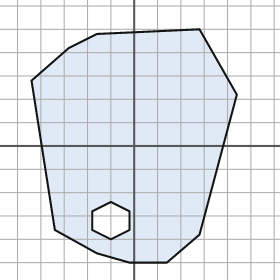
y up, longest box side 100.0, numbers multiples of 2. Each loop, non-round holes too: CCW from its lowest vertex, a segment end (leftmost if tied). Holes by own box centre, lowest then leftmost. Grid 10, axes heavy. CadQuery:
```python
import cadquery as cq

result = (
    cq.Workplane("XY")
    .moveTo(-2.0, -50.0)
    .lineTo(14.0, -50.0)
    .lineTo(28.0, -38.0)
    .lineTo(44.0, 22.0)
    .lineTo(28.0, 50.0)
    .lineTo(-16.0, 48.0)
    .lineTo(-28.0, 42.0)
    .lineTo(-44.0, 28.0)
    .lineTo(-34.0, -36.0)
    .lineTo(-16.0, -46.0)
    .close()
    .moveTo(-10.0, -40.0)
    .lineTo(-2.0, -36.0)
    .lineTo(-2.0, -28.0)
    .lineTo(-10.0, -24.0)
    .lineTo(-18.0, -28.0)
    .lineTo(-18.0, -36.0)
    .close()
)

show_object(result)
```